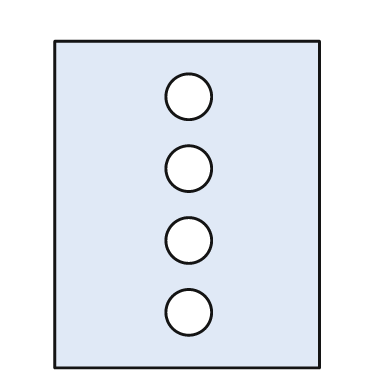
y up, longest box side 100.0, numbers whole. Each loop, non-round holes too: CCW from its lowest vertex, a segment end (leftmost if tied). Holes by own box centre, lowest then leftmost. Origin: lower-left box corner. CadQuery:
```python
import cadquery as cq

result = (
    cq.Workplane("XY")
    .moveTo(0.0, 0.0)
    .lineTo(81.0, 0.0)
    .lineTo(81.0, 100.0)
    .lineTo(0.0, 100.0)
    .close()
    .moveTo(41.0, 17.0)
    .circle(7.0)
    .moveTo(41.0, 39.0)
    .circle(7.0)
    .moveTo(41.0, 61.0)
    .circle(7.0)
    .moveTo(41.0, 83.0)
    .circle(7.0)
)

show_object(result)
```